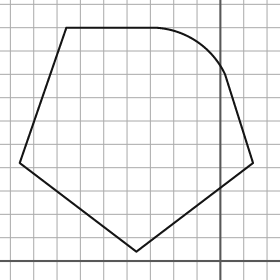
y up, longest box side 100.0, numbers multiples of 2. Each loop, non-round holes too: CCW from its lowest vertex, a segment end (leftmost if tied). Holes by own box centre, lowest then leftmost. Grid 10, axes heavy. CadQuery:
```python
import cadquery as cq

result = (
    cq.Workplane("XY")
    .moveTo(-36.0, 4.0)
    .lineTo(14.0, 42.0)
    .lineTo(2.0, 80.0)
    .threePointArc((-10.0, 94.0), (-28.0, 100.0))
    .lineTo(-66.0, 100.0)
    .lineTo(-86.0, 42.0)
    .close()
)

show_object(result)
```